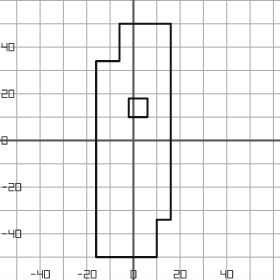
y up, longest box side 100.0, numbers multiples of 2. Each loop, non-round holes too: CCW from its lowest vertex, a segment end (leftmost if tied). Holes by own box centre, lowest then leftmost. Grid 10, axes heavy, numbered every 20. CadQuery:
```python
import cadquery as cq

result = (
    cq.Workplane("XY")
    .moveTo(-16.0, -50.0)
    .lineTo(10.0, -50.0)
    .lineTo(10.0, -34.0)
    .lineTo(16.0, -34.0)
    .lineTo(16.0, 50.0)
    .lineTo(-6.0, 50.0)
    .lineTo(-6.0, 34.0)
    .lineTo(-16.0, 34.0)
    .close()
    .moveTo(-2.0, 10.0)
    .lineTo(6.0, 10.0)
    .lineTo(6.0, 18.0)
    .lineTo(-2.0, 18.0)
    .close()
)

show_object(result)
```